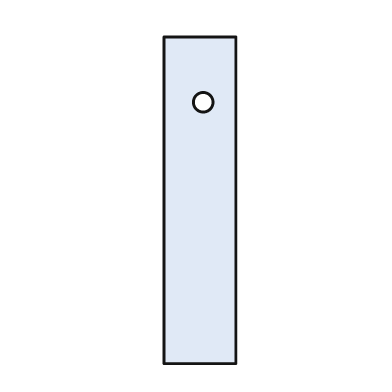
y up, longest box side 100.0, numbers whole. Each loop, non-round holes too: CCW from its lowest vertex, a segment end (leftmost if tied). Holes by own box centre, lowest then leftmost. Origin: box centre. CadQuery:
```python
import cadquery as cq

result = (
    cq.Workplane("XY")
    .moveTo(-11.0, -50.0)
    .lineTo(11.0, -50.0)
    .lineTo(11.0, 50.0)
    .lineTo(-11.0, 50.0)
    .close()
    .moveTo(1.0, 30.0)
    .circle(3.0)
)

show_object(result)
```